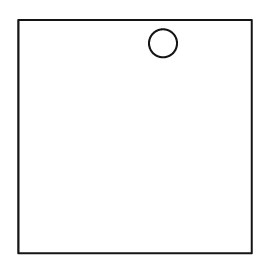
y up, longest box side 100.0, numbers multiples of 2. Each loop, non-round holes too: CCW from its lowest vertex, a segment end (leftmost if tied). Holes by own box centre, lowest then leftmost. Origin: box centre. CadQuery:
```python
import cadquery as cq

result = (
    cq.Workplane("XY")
    .moveTo(-50.0, -50.0)
    .lineTo(50.0, -50.0)
    .lineTo(50.0, 50.0)
    .lineTo(-50.0, 50.0)
    .close()
    .moveTo(12.0, 40.0)
    .circle(6.0)
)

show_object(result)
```